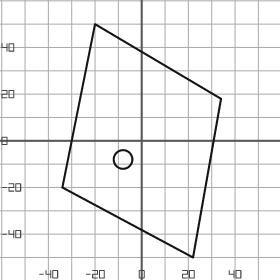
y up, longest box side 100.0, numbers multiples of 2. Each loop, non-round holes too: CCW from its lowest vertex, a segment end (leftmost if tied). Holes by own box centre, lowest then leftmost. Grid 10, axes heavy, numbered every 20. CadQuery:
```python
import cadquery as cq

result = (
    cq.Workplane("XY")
    .moveTo(22.0, -50.0)
    .lineTo(34.0, 18.0)
    .lineTo(-20.0, 50.0)
    .lineTo(-34.0, -20.0)
    .close()
    .moveTo(-8.0, -8.0)
    .circle(4.0)
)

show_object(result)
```